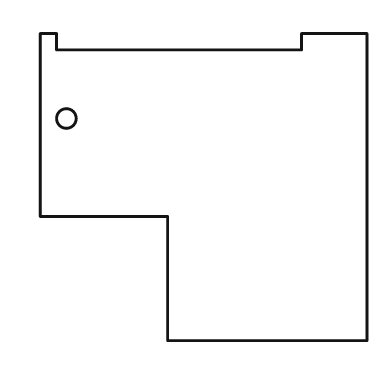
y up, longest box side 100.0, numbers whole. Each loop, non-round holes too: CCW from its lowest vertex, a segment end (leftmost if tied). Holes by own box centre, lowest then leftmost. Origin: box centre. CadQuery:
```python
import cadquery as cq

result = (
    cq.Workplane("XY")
    .moveTo(-11.0, -47.0)
    .lineTo(50.0, -47.0)
    .lineTo(50.0, 47.0)
    .lineTo(30.0, 47.0)
    .lineTo(30.0, 42.0)
    .lineTo(-45.0, 42.0)
    .lineTo(-45.0, 47.0)
    .lineTo(-50.0, 47.0)
    .lineTo(-50.0, -9.0)
    .lineTo(-11.0, -9.0)
    .close()
    .moveTo(-42.0, 21.0)
    .circle(3.0)
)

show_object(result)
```